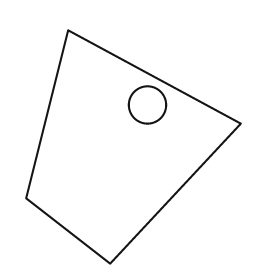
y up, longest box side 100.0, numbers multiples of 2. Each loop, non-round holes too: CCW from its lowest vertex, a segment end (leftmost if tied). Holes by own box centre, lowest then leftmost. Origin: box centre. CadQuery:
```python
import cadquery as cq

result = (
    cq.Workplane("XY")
    .moveTo(-10.0, -50.0)
    .lineTo(46.0, 10.0)
    .lineTo(-28.0, 50.0)
    .lineTo(-46.0, -22.0)
    .close()
    .moveTo(6.0, 18.0)
    .circle(8.0)
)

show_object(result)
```